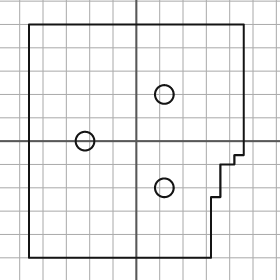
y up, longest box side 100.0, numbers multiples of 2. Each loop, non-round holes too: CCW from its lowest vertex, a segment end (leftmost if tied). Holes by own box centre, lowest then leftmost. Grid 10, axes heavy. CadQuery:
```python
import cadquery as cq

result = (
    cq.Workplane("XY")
    .moveTo(-46.0, -50.0)
    .lineTo(32.0, -50.0)
    .lineTo(32.0, -24.0)
    .lineTo(36.0, -24.0)
    .lineTo(36.0, -10.0)
    .lineTo(42.0, -10.0)
    .lineTo(42.0, -6.0)
    .lineTo(46.0, -6.0)
    .lineTo(46.0, 50.0)
    .lineTo(-46.0, 50.0)
    .close()
    .moveTo(12.0, -20.0)
    .circle(4.0)
    .moveTo(-22.0, 0.0)
    .circle(4.0)
    .moveTo(12.0, 20.0)
    .circle(4.0)
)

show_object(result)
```